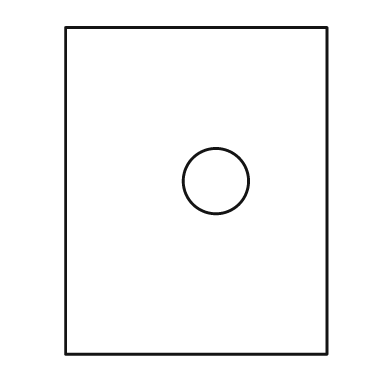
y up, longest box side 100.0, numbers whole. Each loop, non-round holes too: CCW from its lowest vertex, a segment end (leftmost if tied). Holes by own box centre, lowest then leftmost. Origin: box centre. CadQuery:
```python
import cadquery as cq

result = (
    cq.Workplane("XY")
    .moveTo(-40.0, -50.0)
    .lineTo(40.0, -50.0)
    .lineTo(40.0, 50.0)
    .lineTo(-40.0, 50.0)
    .close()
    .moveTo(6.0, 3.0)
    .circle(10.0)
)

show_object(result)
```